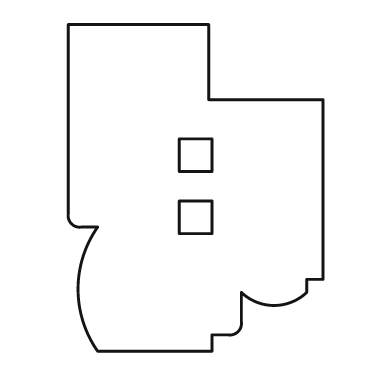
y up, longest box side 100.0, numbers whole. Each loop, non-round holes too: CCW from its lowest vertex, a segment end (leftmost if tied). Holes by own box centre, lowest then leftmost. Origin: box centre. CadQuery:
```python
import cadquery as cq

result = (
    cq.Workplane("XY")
    .moveTo(-30.0, -50.0)
    .lineTo(5.0, -50.0)
    .lineTo(5.0, -45.0)
    .lineTo(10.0, -45.0)
    .threePointArc((13.0, -44.0), (14.0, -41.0))
    .lineTo(14.0, -32.0)
    .threePointArc((24.0, -36.0), (34.0, -32.0))
    .lineTo(34.0, -28.0)
    .lineTo(39.0, -28.0)
    .lineTo(39.0, 27.0)
    .lineTo(4.0, 27.0)
    .lineTo(4.0, 50.0)
    .lineTo(-39.0, 50.0)
    .lineTo(-39.0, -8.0)
    .threePointArc((-38.0, -11.0), (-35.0, -12.0))
    .lineTo(-30.0, -12.0)
    .threePointArc((-36.0, -31.0), (-30.0, -50.0))
    .close()
    .moveTo(-5.0, -14.0)
    .lineTo(5.0, -14.0)
    .lineTo(5.0, -4.0)
    .lineTo(-5.0, -4.0)
    .close()
    .moveTo(-5.0, 5.0)
    .lineTo(5.0, 5.0)
    .lineTo(5.0, 15.0)
    .lineTo(-5.0, 15.0)
    .close()
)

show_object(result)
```